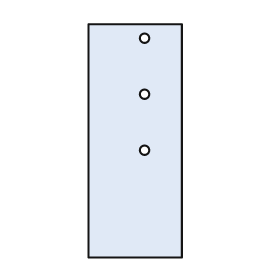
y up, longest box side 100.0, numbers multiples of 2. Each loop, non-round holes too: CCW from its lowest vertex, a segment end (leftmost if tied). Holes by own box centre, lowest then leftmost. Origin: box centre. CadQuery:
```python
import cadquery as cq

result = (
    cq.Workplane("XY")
    .moveTo(-20.0, -50.0)
    .lineTo(20.0, -50.0)
    .lineTo(20.0, 50.0)
    .lineTo(-20.0, 50.0)
    .close()
    .moveTo(4.0, -4.0)
    .circle(2.0)
    .moveTo(4.0, 20.0)
    .circle(2.0)
    .moveTo(4.0, 44.0)
    .circle(2.0)
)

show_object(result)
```